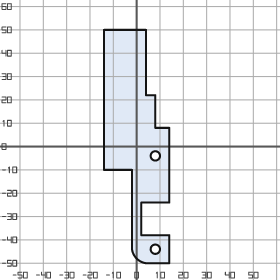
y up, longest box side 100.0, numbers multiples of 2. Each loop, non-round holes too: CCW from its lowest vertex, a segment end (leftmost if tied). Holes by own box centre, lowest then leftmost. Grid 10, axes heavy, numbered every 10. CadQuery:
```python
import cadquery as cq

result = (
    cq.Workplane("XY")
    .moveTo(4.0, -50.0)
    .lineTo(14.0, -50.0)
    .lineTo(14.0, -38.0)
    .lineTo(2.0, -38.0)
    .lineTo(2.0, -24.0)
    .lineTo(14.0, -24.0)
    .lineTo(14.0, 8.0)
    .lineTo(8.0, 8.0)
    .lineTo(8.0, 22.0)
    .lineTo(4.0, 22.0)
    .lineTo(4.0, 50.0)
    .lineTo(-14.0, 50.0)
    .lineTo(-14.0, -10.0)
    .lineTo(-2.0, -10.0)
    .lineTo(-2.0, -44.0)
    .threePointArc((0.0, -48.0), (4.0, -50.0))
    .close()
    .moveTo(8.0, -44.0)
    .circle(2.0)
    .moveTo(8.0, -4.0)
    .circle(2.0)
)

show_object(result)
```